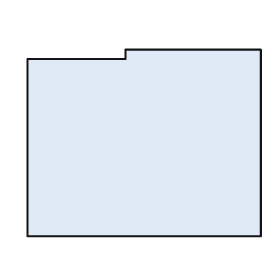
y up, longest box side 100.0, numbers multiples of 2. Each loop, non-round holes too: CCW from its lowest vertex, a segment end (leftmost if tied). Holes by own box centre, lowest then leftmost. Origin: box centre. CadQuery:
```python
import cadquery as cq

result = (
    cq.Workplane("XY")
    .moveTo(-50.0, -40.0)
    .lineTo(50.0, -40.0)
    .lineTo(50.0, 40.0)
    .lineTo(-8.0, 40.0)
    .lineTo(-8.0, 36.0)
    .lineTo(-50.0, 36.0)
    .close()
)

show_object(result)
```